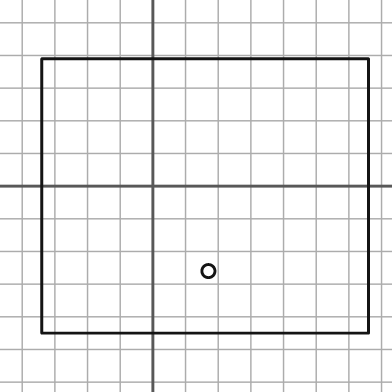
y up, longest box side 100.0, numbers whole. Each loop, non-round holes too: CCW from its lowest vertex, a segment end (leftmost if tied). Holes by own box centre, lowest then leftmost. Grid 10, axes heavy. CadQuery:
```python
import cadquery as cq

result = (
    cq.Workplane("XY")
    .moveTo(-34.0, -45.0)
    .lineTo(66.0, -45.0)
    .lineTo(66.0, 39.0)
    .lineTo(-34.0, 39.0)
    .close()
    .moveTo(17.0, -26.0)
    .circle(2.0)
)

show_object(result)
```